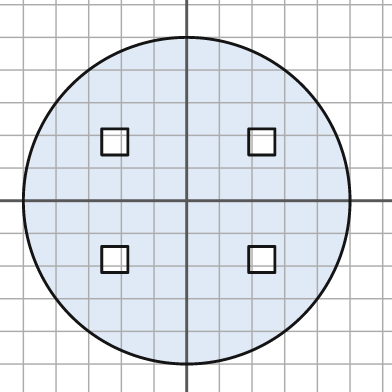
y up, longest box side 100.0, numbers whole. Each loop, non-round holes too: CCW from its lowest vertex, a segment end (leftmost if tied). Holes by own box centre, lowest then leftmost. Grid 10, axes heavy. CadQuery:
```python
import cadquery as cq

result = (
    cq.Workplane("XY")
    .moveTo(0.0, 0.0)
    .circle(50.0)
    .moveTo(-26.0, -22.0)
    .lineTo(-18.0, -22.0)
    .lineTo(-18.0, -14.0)
    .lineTo(-26.0, -14.0)
    .close()
    .moveTo(19.0, -22.0)
    .lineTo(27.0, -22.0)
    .lineTo(27.0, -14.0)
    .lineTo(19.0, -14.0)
    .close()
    .moveTo(-26.0, 14.0)
    .lineTo(-18.0, 14.0)
    .lineTo(-18.0, 22.0)
    .lineTo(-26.0, 22.0)
    .close()
    .moveTo(19.0, 14.0)
    .lineTo(27.0, 14.0)
    .lineTo(27.0, 22.0)
    .lineTo(19.0, 22.0)
    .close()
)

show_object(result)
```